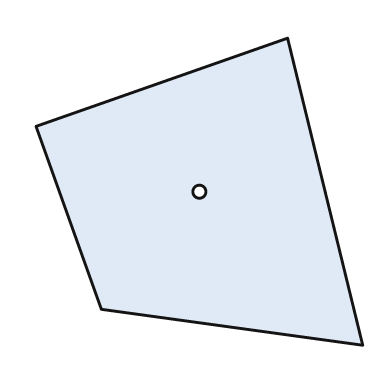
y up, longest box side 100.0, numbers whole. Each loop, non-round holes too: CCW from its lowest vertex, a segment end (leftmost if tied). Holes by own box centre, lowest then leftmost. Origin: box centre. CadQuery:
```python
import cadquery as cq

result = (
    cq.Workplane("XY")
    .moveTo(50.0, -47.0)
    .lineTo(27.0, 47.0)
    .lineTo(-50.0, 20.0)
    .lineTo(-30.0, -36.0)
    .close()
    .moveTo(0.0, 0.0)
    .circle(2.0)
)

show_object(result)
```